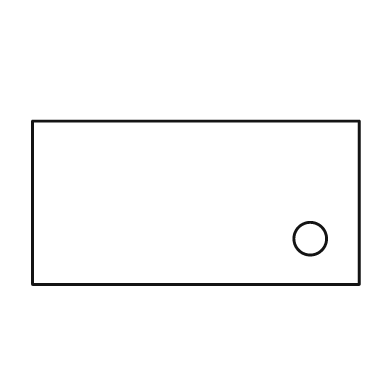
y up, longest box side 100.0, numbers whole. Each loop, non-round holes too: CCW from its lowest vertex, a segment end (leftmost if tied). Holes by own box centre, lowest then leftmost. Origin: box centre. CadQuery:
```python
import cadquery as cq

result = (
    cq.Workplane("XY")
    .moveTo(-50.0, -25.0)
    .lineTo(50.0, -25.0)
    .lineTo(50.0, 25.0)
    .lineTo(-50.0, 25.0)
    .close()
    .moveTo(35.0, -11.0)
    .circle(5.0)
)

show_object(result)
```